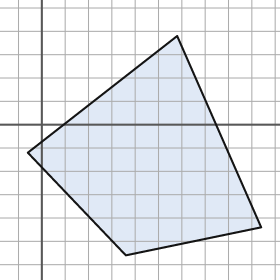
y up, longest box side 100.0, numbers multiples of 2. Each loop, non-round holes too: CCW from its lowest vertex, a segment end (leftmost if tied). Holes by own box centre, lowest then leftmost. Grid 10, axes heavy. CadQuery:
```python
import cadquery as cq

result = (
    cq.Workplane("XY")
    .moveTo(36.0, -56.0)
    .lineTo(94.0, -44.0)
    .lineTo(58.0, 38.0)
    .lineTo(-6.0, -12.0)
    .close()
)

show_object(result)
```